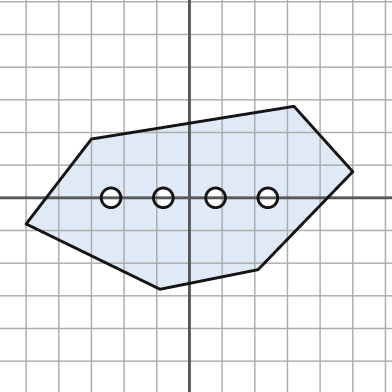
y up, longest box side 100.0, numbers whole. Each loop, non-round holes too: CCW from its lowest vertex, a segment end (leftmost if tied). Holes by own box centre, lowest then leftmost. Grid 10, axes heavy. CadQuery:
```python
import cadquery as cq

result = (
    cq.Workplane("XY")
    .moveTo(-9.0, -28.0)
    .lineTo(21.0, -22.0)
    .lineTo(50.0, 8.0)
    .lineTo(32.0, 28.0)
    .lineTo(-30.0, 18.0)
    .lineTo(-50.0, -8.0)
    .close()
    .moveTo(-24.0, 0.0)
    .circle(3.0)
    .moveTo(-8.0, 0.0)
    .circle(3.0)
    .moveTo(8.0, 0.0)
    .circle(3.0)
    .moveTo(24.0, 0.0)
    .circle(3.0)
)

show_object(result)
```